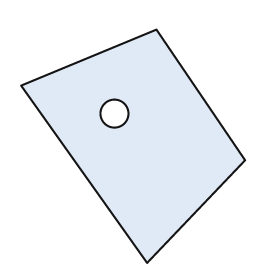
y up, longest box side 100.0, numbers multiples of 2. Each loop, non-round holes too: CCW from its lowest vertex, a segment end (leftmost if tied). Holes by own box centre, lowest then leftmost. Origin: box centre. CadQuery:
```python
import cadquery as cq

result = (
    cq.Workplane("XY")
    .moveTo(6.0, -50.0)
    .lineTo(48.0, -6.0)
    .lineTo(10.0, 50.0)
    .lineTo(-48.0, 26.0)
    .close()
    .moveTo(-8.0, 14.0)
    .circle(6.0)
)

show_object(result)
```